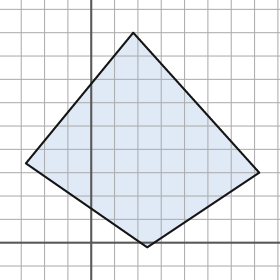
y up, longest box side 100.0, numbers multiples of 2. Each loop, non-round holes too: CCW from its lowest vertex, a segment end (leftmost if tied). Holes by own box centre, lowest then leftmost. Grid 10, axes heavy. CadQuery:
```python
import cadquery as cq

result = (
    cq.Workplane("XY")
    .moveTo(24.0, -2.0)
    .lineTo(72.0, 30.0)
    .lineTo(18.0, 90.0)
    .lineTo(-28.0, 34.0)
    .close()
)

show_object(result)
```